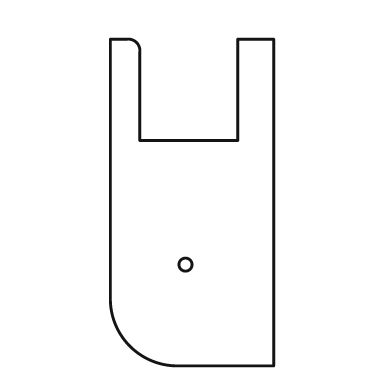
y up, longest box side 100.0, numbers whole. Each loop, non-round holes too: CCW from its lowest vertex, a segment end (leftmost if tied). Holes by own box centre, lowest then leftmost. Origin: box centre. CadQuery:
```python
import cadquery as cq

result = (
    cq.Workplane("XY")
    .moveTo(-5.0, -50.0)
    .lineTo(25.0, -50.0)
    .lineTo(25.0, 50.0)
    .lineTo(14.0, 50.0)
    .lineTo(14.0, 19.0)
    .lineTo(-16.0, 19.0)
    .lineTo(-16.0, 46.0)
    .threePointArc((-17.0, 49.0), (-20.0, 50.0))
    .lineTo(-25.0, 50.0)
    .lineTo(-25.0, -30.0)
    .threePointArc((-19.0, -44.0), (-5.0, -50.0))
    .close()
    .moveTo(-2.0, -19.0)
    .circle(2.0)
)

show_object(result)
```